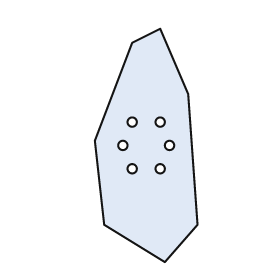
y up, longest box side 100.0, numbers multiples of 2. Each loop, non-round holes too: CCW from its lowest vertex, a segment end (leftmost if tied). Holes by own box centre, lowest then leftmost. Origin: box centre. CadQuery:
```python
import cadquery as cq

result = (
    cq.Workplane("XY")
    .moveTo(8.0, -50.0)
    .lineTo(22.0, -34.0)
    .lineTo(18.0, 22.0)
    .lineTo(6.0, 50.0)
    .lineTo(-6.0, 44.0)
    .lineTo(-22.0, 2.0)
    .lineTo(-18.0, -34.0)
    .close()
    .moveTo(-6.0, -10.0)
    .circle(2.0)
    .moveTo(6.0, -10.0)
    .circle(2.0)
    .moveTo(-10.0, 0.0)
    .circle(2.0)
    .moveTo(10.0, 0.0)
    .circle(2.0)
    .moveTo(-6.0, 10.0)
    .circle(2.0)
    .moveTo(6.0, 10.0)
    .circle(2.0)
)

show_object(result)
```